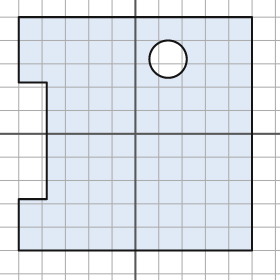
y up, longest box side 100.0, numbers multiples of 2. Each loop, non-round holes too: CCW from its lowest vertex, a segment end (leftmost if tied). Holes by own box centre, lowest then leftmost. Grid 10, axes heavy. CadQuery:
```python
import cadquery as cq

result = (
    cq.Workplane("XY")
    .moveTo(-50.0, -50.0)
    .lineTo(50.0, -50.0)
    .lineTo(50.0, 50.0)
    .lineTo(-50.0, 50.0)
    .lineTo(-50.0, 22.0)
    .lineTo(-38.0, 22.0)
    .lineTo(-38.0, -28.0)
    .lineTo(-50.0, -28.0)
    .close()
    .moveTo(14.0, 32.0)
    .circle(8.0)
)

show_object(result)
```